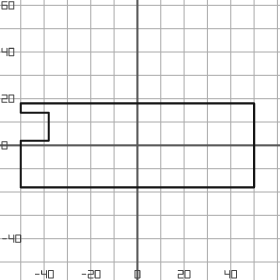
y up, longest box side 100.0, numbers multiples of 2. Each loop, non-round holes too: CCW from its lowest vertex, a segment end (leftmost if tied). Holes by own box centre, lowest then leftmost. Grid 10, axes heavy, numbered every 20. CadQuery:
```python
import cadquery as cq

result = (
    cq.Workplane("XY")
    .moveTo(-50.0, -18.0)
    .lineTo(50.0, -18.0)
    .lineTo(50.0, 18.0)
    .lineTo(-50.0, 18.0)
    .lineTo(-50.0, 14.0)
    .lineTo(-38.0, 14.0)
    .lineTo(-38.0, 2.0)
    .lineTo(-50.0, 2.0)
    .close()
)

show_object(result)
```